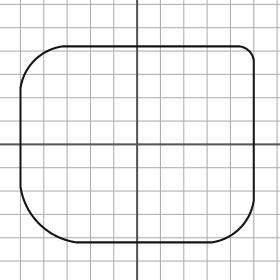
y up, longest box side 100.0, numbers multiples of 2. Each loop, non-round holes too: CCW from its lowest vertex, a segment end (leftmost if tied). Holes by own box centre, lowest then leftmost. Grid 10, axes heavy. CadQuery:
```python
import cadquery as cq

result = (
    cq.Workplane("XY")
    .moveTo(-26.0, -42.0)
    .lineTo(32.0, -42.0)
    .threePointArc((44.0, -36.0), (50.0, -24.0))
    .lineTo(50.0, 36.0)
    .threePointArc((48.0, 40.0), (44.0, 42.0))
    .lineTo(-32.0, 42.0)
    .threePointArc((-44.0, 36.0), (-50.0, 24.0))
    .lineTo(-50.0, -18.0)
    .threePointArc((-42.0, -34.0), (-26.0, -42.0))
    .close()
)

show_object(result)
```